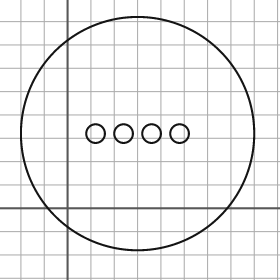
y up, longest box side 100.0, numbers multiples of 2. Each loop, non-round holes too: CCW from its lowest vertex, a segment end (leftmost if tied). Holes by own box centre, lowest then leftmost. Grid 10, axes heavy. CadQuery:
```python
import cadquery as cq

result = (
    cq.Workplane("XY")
    .moveTo(30.0, 32.0)
    .circle(50.0)
    .moveTo(12.0, 32.0)
    .circle(4.0)
    .moveTo(24.0, 32.0)
    .circle(4.0)
    .moveTo(36.0, 32.0)
    .circle(4.0)
    .moveTo(48.0, 32.0)
    .circle(4.0)
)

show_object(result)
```